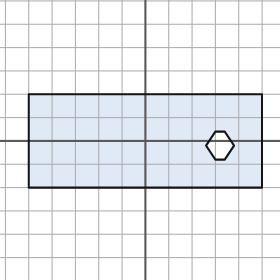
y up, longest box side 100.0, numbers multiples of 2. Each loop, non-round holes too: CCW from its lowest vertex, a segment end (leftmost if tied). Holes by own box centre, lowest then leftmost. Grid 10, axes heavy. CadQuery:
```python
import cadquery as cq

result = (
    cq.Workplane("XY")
    .moveTo(-50.0, -20.0)
    .lineTo(50.0, -20.0)
    .lineTo(50.0, 20.0)
    .lineTo(-50.0, 20.0)
    .close()
    .moveTo(30.0, -8.0)
    .lineTo(34.0, -8.0)
    .lineTo(38.0, -2.0)
    .lineTo(34.0, 4.0)
    .lineTo(30.0, 4.0)
    .lineTo(26.0, -2.0)
    .close()
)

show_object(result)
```